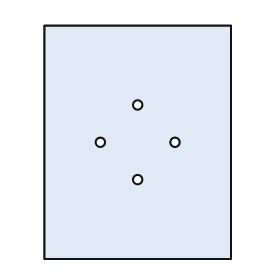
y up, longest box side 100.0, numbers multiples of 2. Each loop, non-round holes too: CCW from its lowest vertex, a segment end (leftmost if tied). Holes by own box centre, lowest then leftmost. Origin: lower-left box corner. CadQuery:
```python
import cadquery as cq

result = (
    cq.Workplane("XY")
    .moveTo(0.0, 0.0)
    .lineTo(80.0, 0.0)
    .lineTo(80.0, 100.0)
    .lineTo(0.0, 100.0)
    .close()
    .moveTo(40.0, 34.0)
    .circle(2.0)
    .moveTo(24.0, 50.0)
    .circle(2.0)
    .moveTo(56.0, 50.0)
    .circle(2.0)
    .moveTo(40.0, 66.0)
    .circle(2.0)
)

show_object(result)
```